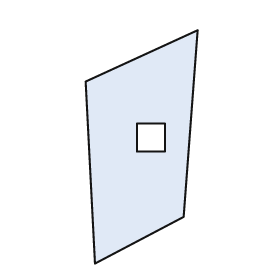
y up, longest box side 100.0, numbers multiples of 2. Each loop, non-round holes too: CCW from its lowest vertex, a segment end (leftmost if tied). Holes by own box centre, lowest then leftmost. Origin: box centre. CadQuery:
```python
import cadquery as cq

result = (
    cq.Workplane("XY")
    .moveTo(-20.0, -50.0)
    .lineTo(18.0, -30.0)
    .lineTo(24.0, 50.0)
    .lineTo(-24.0, 28.0)
    .close()
    .moveTo(-2.0, -2.0)
    .lineTo(10.0, -2.0)
    .lineTo(10.0, 10.0)
    .lineTo(-2.0, 10.0)
    .close()
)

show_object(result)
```